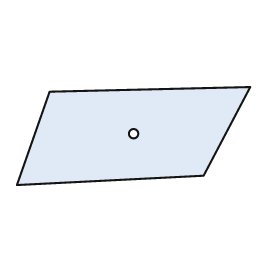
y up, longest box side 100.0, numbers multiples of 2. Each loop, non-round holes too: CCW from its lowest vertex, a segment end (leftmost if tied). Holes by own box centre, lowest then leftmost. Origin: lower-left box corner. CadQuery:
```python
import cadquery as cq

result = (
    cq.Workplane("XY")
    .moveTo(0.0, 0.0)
    .lineTo(80.0, 4.0)
    .lineTo(100.0, 42.0)
    .lineTo(14.0, 40.0)
    .close()
    .moveTo(50.0, 22.0)
    .circle(2.0)
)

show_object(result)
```